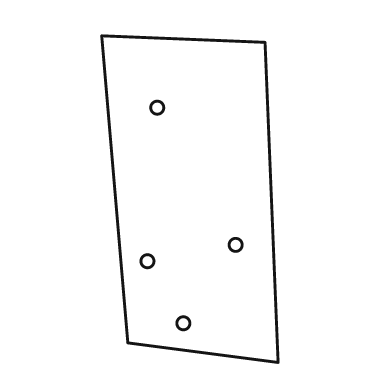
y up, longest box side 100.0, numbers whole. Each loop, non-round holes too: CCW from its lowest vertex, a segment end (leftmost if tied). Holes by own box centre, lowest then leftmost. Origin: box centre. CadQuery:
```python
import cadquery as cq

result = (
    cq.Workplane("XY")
    .moveTo(27.0, -50.0)
    .lineTo(23.0, 48.0)
    .lineTo(-27.0, 50.0)
    .lineTo(-19.0, -44.0)
    .close()
    .moveTo(-2.0, -38.0)
    .circle(2.0)
    .moveTo(-13.0, -19.0)
    .circle(2.0)
    .moveTo(14.0, -14.0)
    .circle(2.0)
    .moveTo(-10.0, 28.0)
    .circle(2.0)
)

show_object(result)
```